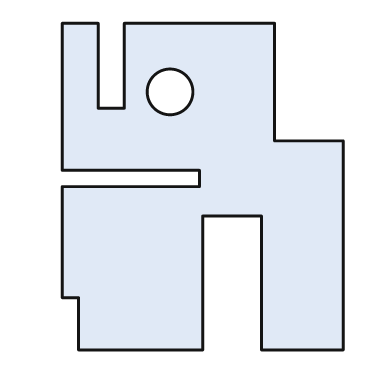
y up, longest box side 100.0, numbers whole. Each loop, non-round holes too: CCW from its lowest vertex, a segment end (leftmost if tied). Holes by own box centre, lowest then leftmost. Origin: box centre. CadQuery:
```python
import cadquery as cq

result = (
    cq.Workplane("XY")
    .moveTo(-38.0, -50.0)
    .lineTo(0.0, -50.0)
    .lineTo(0.0, -9.0)
    .lineTo(18.0, -9.0)
    .lineTo(18.0, -50.0)
    .lineTo(43.0, -50.0)
    .lineTo(43.0, 14.0)
    .lineTo(22.0, 14.0)
    .lineTo(22.0, 50.0)
    .lineTo(-24.0, 50.0)
    .lineTo(-24.0, 24.0)
    .lineTo(-32.0, 24.0)
    .lineTo(-32.0, 50.0)
    .lineTo(-43.0, 50.0)
    .lineTo(-43.0, 5.0)
    .lineTo(-1.0, 5.0)
    .lineTo(-1.0, 0.0)
    .lineTo(-43.0, 0.0)
    .lineTo(-43.0, -34.0)
    .lineTo(-38.0, -34.0)
    .close()
    .moveTo(-10.0, 29.0)
    .circle(7.0)
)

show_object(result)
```